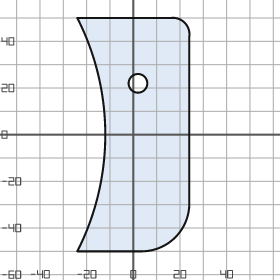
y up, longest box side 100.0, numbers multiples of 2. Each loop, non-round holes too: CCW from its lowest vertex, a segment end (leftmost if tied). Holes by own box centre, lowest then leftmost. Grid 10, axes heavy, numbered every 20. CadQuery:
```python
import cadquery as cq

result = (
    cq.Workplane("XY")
    .moveTo(-24.0, -50.0)
    .lineTo(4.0, -50.0)
    .threePointArc((18.0, -44.0), (24.0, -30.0))
    .lineTo(24.0, 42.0)
    .threePointArc((22.0, 48.0), (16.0, 50.0))
    .lineTo(-24.0, 50.0)
    .threePointArc((-12.0, 0.0), (-24.0, -50.0))
    .close()
    .moveTo(2.0, 22.0)
    .circle(4.0)
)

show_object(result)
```